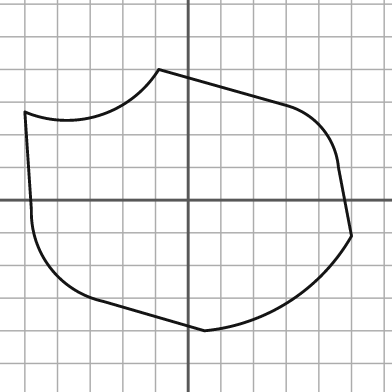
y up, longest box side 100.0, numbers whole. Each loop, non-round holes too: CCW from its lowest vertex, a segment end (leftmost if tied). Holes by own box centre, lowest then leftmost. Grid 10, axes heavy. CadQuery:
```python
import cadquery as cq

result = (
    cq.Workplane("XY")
    .moveTo(5.0, -40.0)
    .threePointArc((31.0, -31.0), (50.0, -11.0))
    .lineTo(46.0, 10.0)
    .threePointArc((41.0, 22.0), (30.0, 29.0))
    .lineTo(-9.0, 40.0)
    .threePointArc((-27.0, 26.0), (-50.0, 27.0))
    .lineTo(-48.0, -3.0)
    .threePointArc((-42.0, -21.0), (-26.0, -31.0))
    .close()
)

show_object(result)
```